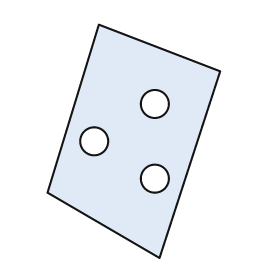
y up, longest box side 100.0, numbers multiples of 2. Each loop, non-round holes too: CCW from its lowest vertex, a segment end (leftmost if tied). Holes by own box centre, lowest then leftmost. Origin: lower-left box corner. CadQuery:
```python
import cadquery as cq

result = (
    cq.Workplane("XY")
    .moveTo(48.0, 0.0)
    .lineTo(74.0, 80.0)
    .lineTo(22.0, 100.0)
    .lineTo(0.0, 28.0)
    .close()
    .moveTo(46.0, 34.0)
    .circle(6.0)
    .moveTo(20.0, 50.0)
    .circle(6.0)
    .moveTo(46.0, 66.0)
    .circle(6.0)
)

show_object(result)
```